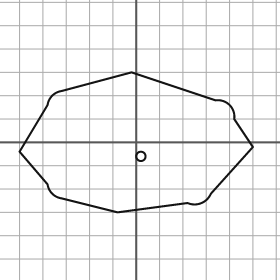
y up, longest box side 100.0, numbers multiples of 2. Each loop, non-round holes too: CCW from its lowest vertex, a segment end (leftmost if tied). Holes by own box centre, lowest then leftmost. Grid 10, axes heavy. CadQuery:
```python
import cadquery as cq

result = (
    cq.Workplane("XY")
    .moveTo(-8.0, -30.0)
    .lineTo(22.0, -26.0)
    .threePointArc((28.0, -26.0), (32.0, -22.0))
    .lineTo(50.0, -2.0)
    .lineTo(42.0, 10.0)
    .threePointArc((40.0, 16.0), (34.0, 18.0))
    .lineTo(-2.0, 30.0)
    .lineTo(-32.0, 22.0)
    .threePointArc((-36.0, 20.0), (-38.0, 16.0))
    .lineTo(-50.0, -4.0)
    .lineTo(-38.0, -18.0)
    .threePointArc((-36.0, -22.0), (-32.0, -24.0))
    .close()
    .moveTo(2.0, -6.0)
    .circle(2.0)
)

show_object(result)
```